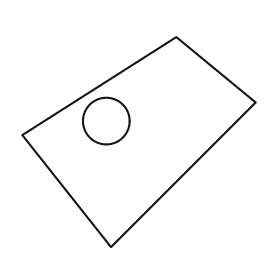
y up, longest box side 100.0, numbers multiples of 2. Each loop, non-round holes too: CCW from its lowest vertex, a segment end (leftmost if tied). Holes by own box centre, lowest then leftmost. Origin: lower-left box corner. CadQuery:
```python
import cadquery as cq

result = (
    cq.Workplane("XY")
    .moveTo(38.0, 0.0)
    .lineTo(100.0, 62.0)
    .lineTo(66.0, 90.0)
    .lineTo(0.0, 48.0)
    .close()
    .moveTo(36.0, 54.0)
    .circle(10.0)
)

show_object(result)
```